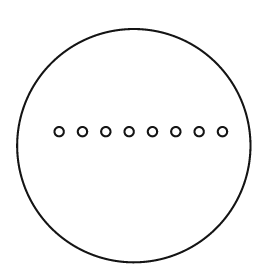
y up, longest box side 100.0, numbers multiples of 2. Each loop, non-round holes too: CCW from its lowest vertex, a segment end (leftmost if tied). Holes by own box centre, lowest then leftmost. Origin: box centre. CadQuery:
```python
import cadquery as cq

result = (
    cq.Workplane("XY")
    .moveTo(0.0, 0.0)
    .circle(50.0)
    .moveTo(-32.0, 6.0)
    .circle(2.0)
    .moveTo(-22.0, 6.0)
    .circle(2.0)
    .moveTo(-12.0, 6.0)
    .circle(2.0)
    .moveTo(-2.0, 6.0)
    .circle(2.0)
    .moveTo(8.0, 6.0)
    .circle(2.0)
    .moveTo(18.0, 6.0)
    .circle(2.0)
    .moveTo(28.0, 6.0)
    .circle(2.0)
    .moveTo(38.0, 6.0)
    .circle(2.0)
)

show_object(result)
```